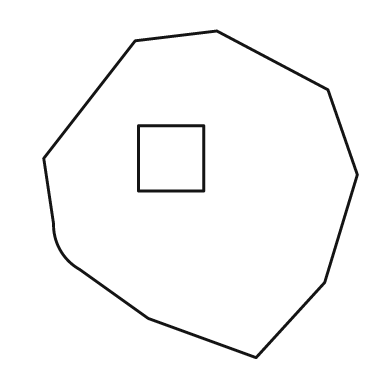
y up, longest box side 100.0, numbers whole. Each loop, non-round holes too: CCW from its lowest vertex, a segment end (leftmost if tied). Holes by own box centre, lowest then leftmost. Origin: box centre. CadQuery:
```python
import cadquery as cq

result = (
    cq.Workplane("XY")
    .moveTo(17.0, -50.0)
    .lineTo(38.0, -27.0)
    .lineTo(48.0, 6.0)
    .lineTo(39.0, 32.0)
    .lineTo(5.0, 50.0)
    .lineTo(-20.0, 47.0)
    .lineTo(-48.0, 11.0)
    .lineTo(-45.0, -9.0)
    .threePointArc((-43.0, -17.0), (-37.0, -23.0))
    .lineTo(-16.0, -38.0)
    .close()
    .moveTo(-19.0, 1.0)
    .lineTo(1.0, 1.0)
    .lineTo(1.0, 21.0)
    .lineTo(-19.0, 21.0)
    .close()
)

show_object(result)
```